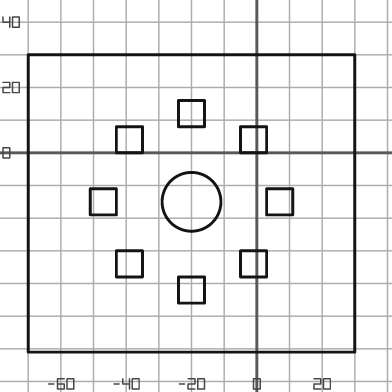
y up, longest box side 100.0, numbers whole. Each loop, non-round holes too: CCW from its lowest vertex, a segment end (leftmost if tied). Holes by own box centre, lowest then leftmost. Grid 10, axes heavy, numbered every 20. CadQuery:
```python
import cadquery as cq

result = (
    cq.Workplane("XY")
    .moveTo(-70.0, -61.0)
    .lineTo(30.0, -61.0)
    .lineTo(30.0, 30.0)
    .lineTo(-70.0, 30.0)
    .close()
    .moveTo(-24.0, -46.0)
    .lineTo(-16.0, -46.0)
    .lineTo(-16.0, -38.0)
    .lineTo(-24.0, -38.0)
    .close()
    .moveTo(-43.0, -38.0)
    .lineTo(-35.0, -38.0)
    .lineTo(-35.0, -30.0)
    .lineTo(-43.0, -30.0)
    .close()
    .moveTo(-5.0, -38.0)
    .lineTo(3.0, -38.0)
    .lineTo(3.0, -30.0)
    .lineTo(-5.0, -30.0)
    .close()
    .moveTo(-51.0, -19.0)
    .lineTo(-43.0, -19.0)
    .lineTo(-43.0, -11.0)
    .lineTo(-51.0, -11.0)
    .close()
    .moveTo(-20.0, -15.0)
    .circle(9.0)
    .moveTo(3.0, -19.0)
    .lineTo(11.0, -19.0)
    .lineTo(11.0, -11.0)
    .lineTo(3.0, -11.0)
    .close()
    .moveTo(-43.0, 0.0)
    .lineTo(-35.0, 0.0)
    .lineTo(-35.0, 8.0)
    .lineTo(-43.0, 8.0)
    .close()
    .moveTo(-5.0, 0.0)
    .lineTo(3.0, 0.0)
    .lineTo(3.0, 8.0)
    .lineTo(-5.0, 8.0)
    .close()
    .moveTo(-24.0, 8.0)
    .lineTo(-16.0, 8.0)
    .lineTo(-16.0, 16.0)
    .lineTo(-24.0, 16.0)
    .close()
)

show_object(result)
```